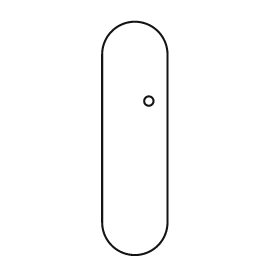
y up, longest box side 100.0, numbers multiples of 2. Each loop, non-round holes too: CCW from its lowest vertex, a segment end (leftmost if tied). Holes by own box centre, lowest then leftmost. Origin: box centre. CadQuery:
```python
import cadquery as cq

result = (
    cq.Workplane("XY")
    .moveTo(-14.0, -36.0)
    .threePointArc((0.0, -50.0), (14.0, -36.0))
    .lineTo(14.0, 36.0)
    .threePointArc((0.0, 50.0), (-14.0, 36.0))
    .close()
    .moveTo(6.0, 16.0)
    .circle(2.0)
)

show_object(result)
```